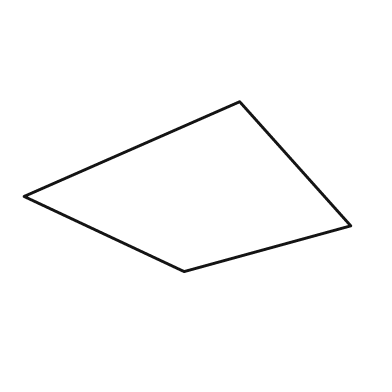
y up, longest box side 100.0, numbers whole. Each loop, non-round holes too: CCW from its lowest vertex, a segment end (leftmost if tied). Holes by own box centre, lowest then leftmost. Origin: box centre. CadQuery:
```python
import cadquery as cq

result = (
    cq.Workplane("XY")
    .moveTo(-1.0, -26.0)
    .lineTo(50.0, -12.0)
    .lineTo(16.0, 26.0)
    .lineTo(-50.0, -3.0)
    .close()
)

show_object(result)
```